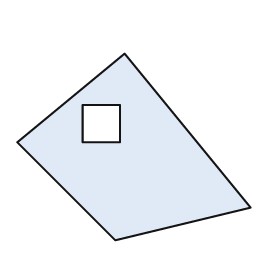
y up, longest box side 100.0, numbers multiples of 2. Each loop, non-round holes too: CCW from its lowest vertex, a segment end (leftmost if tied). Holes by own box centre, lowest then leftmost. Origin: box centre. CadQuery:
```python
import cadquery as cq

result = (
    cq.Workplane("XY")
    .moveTo(-8.0, -40.0)
    .lineTo(50.0, -26.0)
    .lineTo(-4.0, 40.0)
    .lineTo(-50.0, 2.0)
    .close()
    .moveTo(-22.0, 2.0)
    .lineTo(-6.0, 2.0)
    .lineTo(-6.0, 18.0)
    .lineTo(-22.0, 18.0)
    .close()
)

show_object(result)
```